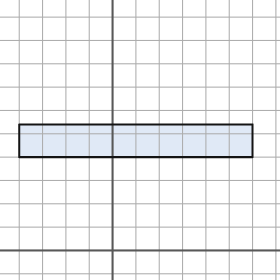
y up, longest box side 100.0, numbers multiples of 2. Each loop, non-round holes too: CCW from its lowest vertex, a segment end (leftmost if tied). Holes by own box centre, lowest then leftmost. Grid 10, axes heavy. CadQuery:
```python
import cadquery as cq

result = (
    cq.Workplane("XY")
    .moveTo(-40.0, 40.0)
    .lineTo(60.0, 40.0)
    .lineTo(60.0, 54.0)
    .lineTo(-40.0, 54.0)
    .close()
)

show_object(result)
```